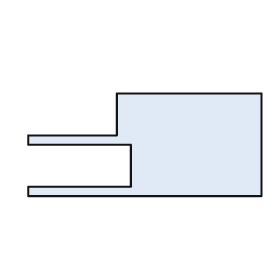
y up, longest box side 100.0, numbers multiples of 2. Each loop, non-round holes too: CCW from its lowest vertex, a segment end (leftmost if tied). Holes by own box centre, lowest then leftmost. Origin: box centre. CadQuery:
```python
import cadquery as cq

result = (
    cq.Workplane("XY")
    .moveTo(-50.0, -22.0)
    .lineTo(50.0, -22.0)
    .lineTo(50.0, 22.0)
    .lineTo(-12.0, 22.0)
    .lineTo(-12.0, 4.0)
    .lineTo(-50.0, 4.0)
    .lineTo(-50.0, 0.0)
    .lineTo(-6.0, 0.0)
    .lineTo(-6.0, -18.0)
    .lineTo(-50.0, -18.0)
    .close()
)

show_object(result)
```